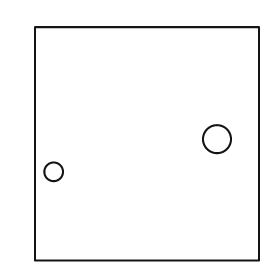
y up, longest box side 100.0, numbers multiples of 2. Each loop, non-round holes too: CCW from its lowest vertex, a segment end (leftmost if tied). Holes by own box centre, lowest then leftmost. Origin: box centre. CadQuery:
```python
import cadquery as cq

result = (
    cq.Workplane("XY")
    .moveTo(-48.0, -50.0)
    .lineTo(48.0, -50.0)
    .lineTo(48.0, 50.0)
    .lineTo(-48.0, 50.0)
    .close()
    .moveTo(-40.0, -12.0)
    .circle(4.0)
    .moveTo(30.0, 2.0)
    .circle(6.0)
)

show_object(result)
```